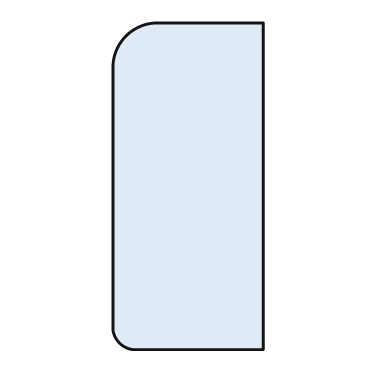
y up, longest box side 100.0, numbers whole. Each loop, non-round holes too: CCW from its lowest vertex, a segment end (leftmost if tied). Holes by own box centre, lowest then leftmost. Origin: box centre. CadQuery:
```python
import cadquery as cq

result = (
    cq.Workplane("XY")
    .moveTo(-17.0, -50.0)
    .lineTo(23.0, -50.0)
    .lineTo(23.0, 50.0)
    .lineTo(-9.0, 50.0)
    .threePointArc((-19.0, 46.0), (-23.0, 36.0))
    .lineTo(-23.0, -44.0)
    .threePointArc((-21.0, -48.0), (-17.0, -50.0))
    .close()
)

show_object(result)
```